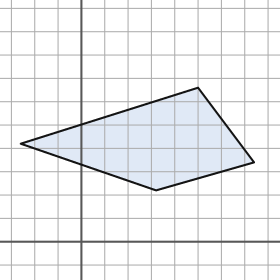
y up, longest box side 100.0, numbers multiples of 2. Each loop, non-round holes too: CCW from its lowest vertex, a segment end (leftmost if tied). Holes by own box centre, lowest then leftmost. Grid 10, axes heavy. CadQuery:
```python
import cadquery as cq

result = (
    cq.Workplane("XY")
    .moveTo(32.0, 22.0)
    .lineTo(74.0, 34.0)
    .lineTo(50.0, 66.0)
    .lineTo(-26.0, 42.0)
    .close()
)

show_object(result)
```